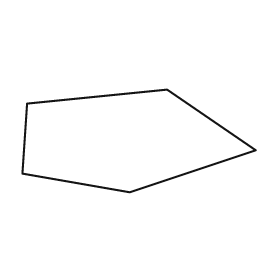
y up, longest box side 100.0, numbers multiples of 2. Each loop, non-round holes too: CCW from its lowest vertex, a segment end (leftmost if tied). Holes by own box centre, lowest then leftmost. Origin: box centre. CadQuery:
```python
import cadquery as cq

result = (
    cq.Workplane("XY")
    .moveTo(-4.0, -22.0)
    .lineTo(50.0, -4.0)
    .lineTo(12.0, 22.0)
    .lineTo(-48.0, 16.0)
    .lineTo(-50.0, -14.0)
    .close()
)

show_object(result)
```